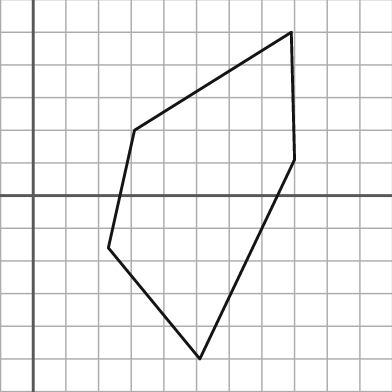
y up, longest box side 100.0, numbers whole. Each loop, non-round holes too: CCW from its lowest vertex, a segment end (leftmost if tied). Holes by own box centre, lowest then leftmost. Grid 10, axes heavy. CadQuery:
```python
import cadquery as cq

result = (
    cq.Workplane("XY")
    .moveTo(51.0, -50.0)
    .lineTo(80.0, 11.0)
    .lineTo(79.0, 50.0)
    .lineTo(31.0, 20.0)
    .lineTo(23.0, -16.0)
    .close()
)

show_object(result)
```